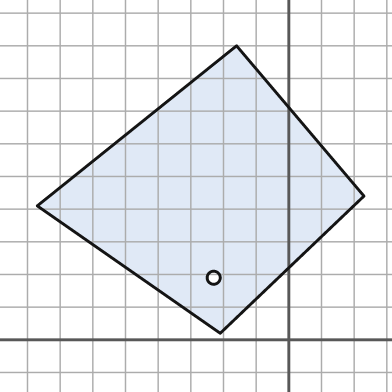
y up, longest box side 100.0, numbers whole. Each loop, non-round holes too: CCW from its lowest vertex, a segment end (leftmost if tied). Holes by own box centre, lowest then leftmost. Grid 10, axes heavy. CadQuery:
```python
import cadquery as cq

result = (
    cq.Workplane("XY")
    .moveTo(-21.0, 2.0)
    .lineTo(23.0, 44.0)
    .lineTo(-16.0, 90.0)
    .lineTo(-77.0, 41.0)
    .close()
    .moveTo(-23.0, 19.0)
    .circle(2.0)
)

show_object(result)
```